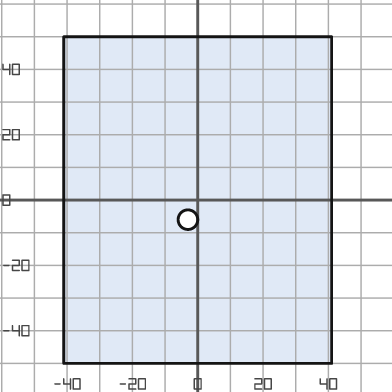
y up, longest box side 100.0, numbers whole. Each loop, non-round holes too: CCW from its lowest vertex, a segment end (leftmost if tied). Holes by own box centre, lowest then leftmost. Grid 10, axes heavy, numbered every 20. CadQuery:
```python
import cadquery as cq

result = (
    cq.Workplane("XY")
    .moveTo(-41.0, -50.0)
    .lineTo(41.0, -50.0)
    .lineTo(41.0, 50.0)
    .lineTo(-41.0, 50.0)
    .close()
    .moveTo(-3.0, -6.0)
    .circle(3.0)
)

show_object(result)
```